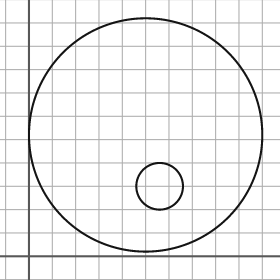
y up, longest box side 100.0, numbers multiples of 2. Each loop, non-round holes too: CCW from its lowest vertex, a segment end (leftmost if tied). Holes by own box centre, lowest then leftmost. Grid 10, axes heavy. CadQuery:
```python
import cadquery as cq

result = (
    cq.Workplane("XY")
    .moveTo(50.0, 52.0)
    .circle(50.0)
    .moveTo(56.0, 30.0)
    .circle(10.0)
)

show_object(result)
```